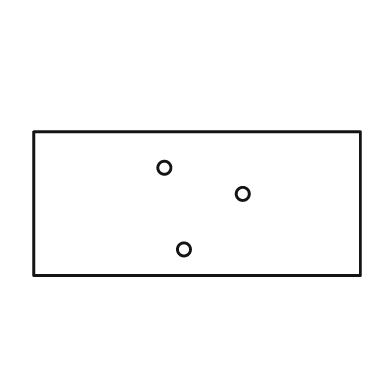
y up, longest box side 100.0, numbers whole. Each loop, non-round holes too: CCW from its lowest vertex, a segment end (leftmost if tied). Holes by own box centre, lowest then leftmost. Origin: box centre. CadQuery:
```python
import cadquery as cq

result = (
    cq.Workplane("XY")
    .moveTo(-50.0, -22.0)
    .lineTo(50.0, -22.0)
    .lineTo(50.0, 22.0)
    .lineTo(-50.0, 22.0)
    .close()
    .moveTo(-4.0, -14.0)
    .circle(2.0)
    .moveTo(14.0, 3.0)
    .circle(2.0)
    .moveTo(-10.0, 11.0)
    .circle(2.0)
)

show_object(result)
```